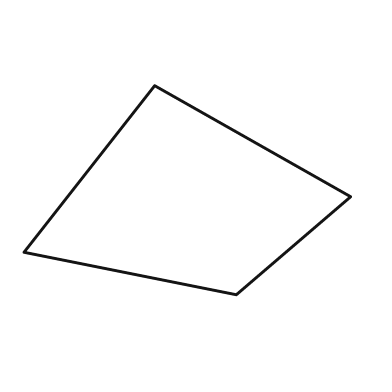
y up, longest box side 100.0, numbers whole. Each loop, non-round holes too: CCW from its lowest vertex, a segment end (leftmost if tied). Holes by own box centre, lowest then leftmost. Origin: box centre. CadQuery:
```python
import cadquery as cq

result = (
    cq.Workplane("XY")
    .moveTo(15.0, -32.0)
    .lineTo(50.0, -2.0)
    .lineTo(-10.0, 32.0)
    .lineTo(-50.0, -19.0)
    .close()
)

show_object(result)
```